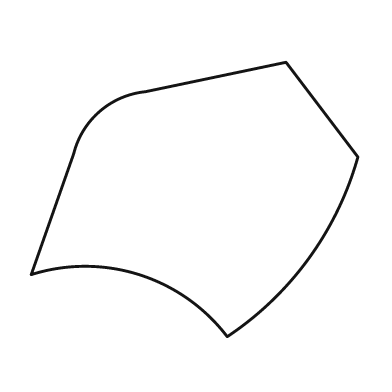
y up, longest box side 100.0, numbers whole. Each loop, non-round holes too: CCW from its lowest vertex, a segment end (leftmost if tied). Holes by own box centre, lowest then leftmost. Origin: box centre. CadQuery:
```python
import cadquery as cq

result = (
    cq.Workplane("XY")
    .moveTo(10.0, -42.0)
    .threePointArc((35.0, -18.0), (50.0, 13.0))
    .lineTo(28.0, 42.0)
    .lineTo(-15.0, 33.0)
    .threePointArc((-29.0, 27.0), (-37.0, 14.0))
    .lineTo(-50.0, -23.0)
    .threePointArc((-17.0, -23.0), (10.0, -42.0))
    .close()
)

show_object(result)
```